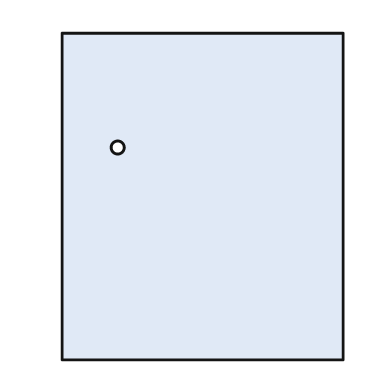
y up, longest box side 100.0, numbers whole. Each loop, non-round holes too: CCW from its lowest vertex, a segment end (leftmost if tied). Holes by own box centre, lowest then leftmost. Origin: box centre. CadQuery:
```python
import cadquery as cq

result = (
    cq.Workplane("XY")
    .moveTo(-43.0, -50.0)
    .lineTo(43.0, -50.0)
    .lineTo(43.0, 50.0)
    .lineTo(-43.0, 50.0)
    .close()
    .moveTo(-26.0, 15.0)
    .circle(2.0)
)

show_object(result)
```